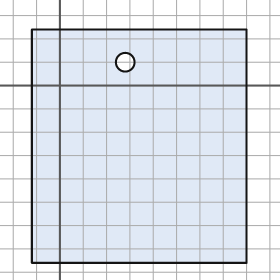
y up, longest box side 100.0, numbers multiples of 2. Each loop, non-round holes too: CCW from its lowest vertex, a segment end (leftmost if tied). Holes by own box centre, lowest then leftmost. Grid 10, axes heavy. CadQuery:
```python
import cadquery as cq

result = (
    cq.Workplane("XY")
    .moveTo(-12.0, -76.0)
    .lineTo(80.0, -76.0)
    .lineTo(80.0, 24.0)
    .lineTo(-12.0, 24.0)
    .close()
    .moveTo(28.0, 10.0)
    .circle(4.0)
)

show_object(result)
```